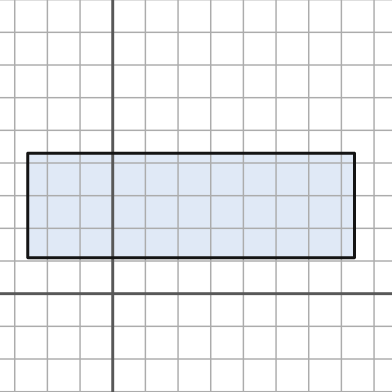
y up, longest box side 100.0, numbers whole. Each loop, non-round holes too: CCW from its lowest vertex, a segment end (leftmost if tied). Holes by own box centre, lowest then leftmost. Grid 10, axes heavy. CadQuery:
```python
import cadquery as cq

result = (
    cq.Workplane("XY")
    .moveTo(-26.0, 11.0)
    .lineTo(74.0, 11.0)
    .lineTo(74.0, 43.0)
    .lineTo(-26.0, 43.0)
    .close()
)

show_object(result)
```